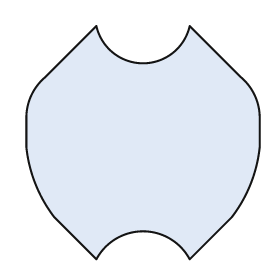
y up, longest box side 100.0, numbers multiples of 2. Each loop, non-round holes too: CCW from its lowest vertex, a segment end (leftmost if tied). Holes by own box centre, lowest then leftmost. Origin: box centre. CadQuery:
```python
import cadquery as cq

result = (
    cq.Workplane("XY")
    .moveTo(-20.0, -50.0)
    .threePointArc((0.0, -38.0), (20.0, -50.0))
    .lineTo(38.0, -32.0)
    .threePointArc((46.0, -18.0), (50.0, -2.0))
    .lineTo(50.0, 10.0)
    .threePointArc((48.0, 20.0), (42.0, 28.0))
    .lineTo(20.0, 50.0)
    .threePointArc((0.0, 34.0), (-20.0, 50.0))
    .lineTo(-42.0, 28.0)
    .threePointArc((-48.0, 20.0), (-50.0, 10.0))
    .lineTo(-50.0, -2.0)
    .threePointArc((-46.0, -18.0), (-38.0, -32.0))
    .close()
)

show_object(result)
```